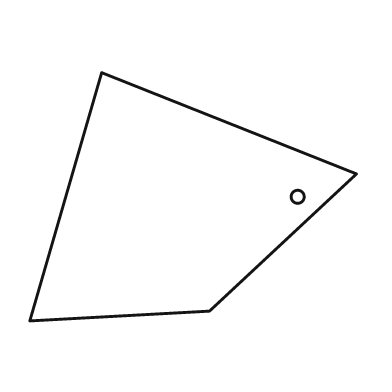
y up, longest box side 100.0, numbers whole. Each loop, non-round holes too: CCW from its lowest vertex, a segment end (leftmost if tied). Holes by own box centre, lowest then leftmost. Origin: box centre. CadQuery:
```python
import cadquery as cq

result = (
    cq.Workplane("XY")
    .moveTo(-50.0, -38.0)
    .lineTo(5.0, -35.0)
    .lineTo(50.0, 7.0)
    .lineTo(-28.0, 38.0)
    .close()
    .moveTo(32.0, 0.0)
    .circle(2.0)
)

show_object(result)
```